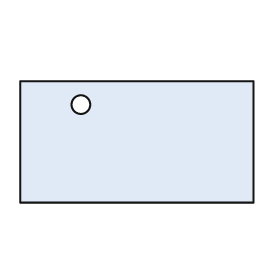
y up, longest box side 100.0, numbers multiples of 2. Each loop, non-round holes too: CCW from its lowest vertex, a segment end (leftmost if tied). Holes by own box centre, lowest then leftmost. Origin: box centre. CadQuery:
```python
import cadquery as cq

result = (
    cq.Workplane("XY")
    .moveTo(-50.0, -26.0)
    .lineTo(50.0, -26.0)
    .lineTo(50.0, 26.0)
    .lineTo(-50.0, 26.0)
    .close()
    .moveTo(-24.0, 16.0)
    .circle(4.0)
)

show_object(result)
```